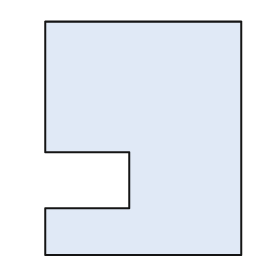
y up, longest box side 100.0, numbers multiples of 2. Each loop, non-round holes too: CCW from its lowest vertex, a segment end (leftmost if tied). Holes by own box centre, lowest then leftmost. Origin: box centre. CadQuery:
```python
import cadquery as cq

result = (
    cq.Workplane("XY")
    .moveTo(-42.0, -50.0)
    .lineTo(42.0, -50.0)
    .lineTo(42.0, 50.0)
    .lineTo(-42.0, 50.0)
    .lineTo(-42.0, -6.0)
    .lineTo(-6.0, -6.0)
    .lineTo(-6.0, -30.0)
    .lineTo(-42.0, -30.0)
    .close()
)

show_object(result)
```